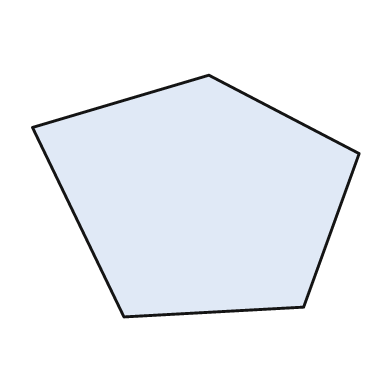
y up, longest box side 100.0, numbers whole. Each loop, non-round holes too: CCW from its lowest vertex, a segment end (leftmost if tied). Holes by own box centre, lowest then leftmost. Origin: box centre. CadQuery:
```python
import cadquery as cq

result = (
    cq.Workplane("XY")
    .moveTo(-22.0, -37.0)
    .lineTo(33.0, -34.0)
    .lineTo(50.0, 13.0)
    .lineTo(4.0, 37.0)
    .lineTo(-50.0, 21.0)
    .close()
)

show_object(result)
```